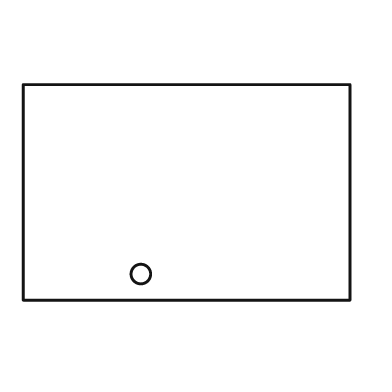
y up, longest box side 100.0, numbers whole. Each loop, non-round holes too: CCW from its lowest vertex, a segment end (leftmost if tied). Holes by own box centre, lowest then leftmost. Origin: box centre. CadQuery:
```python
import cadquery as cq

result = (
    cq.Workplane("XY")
    .moveTo(-50.0, -33.0)
    .lineTo(50.0, -33.0)
    .lineTo(50.0, 33.0)
    .lineTo(-50.0, 33.0)
    .close()
    .moveTo(-14.0, -25.0)
    .circle(3.0)
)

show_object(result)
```